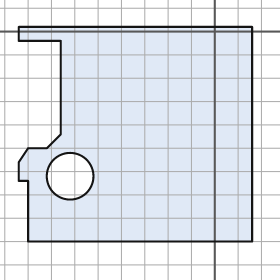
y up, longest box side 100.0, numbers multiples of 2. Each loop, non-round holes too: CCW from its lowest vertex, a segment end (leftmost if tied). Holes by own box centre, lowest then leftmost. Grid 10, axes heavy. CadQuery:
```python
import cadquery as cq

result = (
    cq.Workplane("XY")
    .moveTo(-80.0, -90.0)
    .lineTo(16.0, -90.0)
    .lineTo(16.0, 2.0)
    .lineTo(-84.0, 2.0)
    .lineTo(-84.0, -4.0)
    .lineTo(-66.0, -4.0)
    .lineTo(-66.0, -44.0)
    .lineTo(-72.0, -50.0)
    .lineTo(-80.0, -50.0)
    .lineTo(-84.0, -56.0)
    .lineTo(-84.0, -64.0)
    .lineTo(-80.0, -64.0)
    .close()
    .moveTo(-62.0, -62.0)
    .circle(10.0)
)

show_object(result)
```